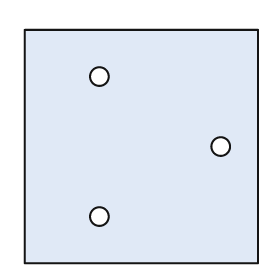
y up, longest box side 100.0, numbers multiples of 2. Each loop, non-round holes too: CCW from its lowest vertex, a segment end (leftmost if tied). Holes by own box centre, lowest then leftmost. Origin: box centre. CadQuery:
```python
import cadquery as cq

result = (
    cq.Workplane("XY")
    .moveTo(-50.0, -50.0)
    .lineTo(50.0, -50.0)
    .lineTo(50.0, 50.0)
    .lineTo(-50.0, 50.0)
    .close()
    .moveTo(-18.0, -30.0)
    .circle(4.0)
    .moveTo(34.0, 0.0)
    .circle(4.0)
    .moveTo(-18.0, 30.0)
    .circle(4.0)
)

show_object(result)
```